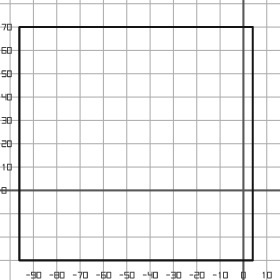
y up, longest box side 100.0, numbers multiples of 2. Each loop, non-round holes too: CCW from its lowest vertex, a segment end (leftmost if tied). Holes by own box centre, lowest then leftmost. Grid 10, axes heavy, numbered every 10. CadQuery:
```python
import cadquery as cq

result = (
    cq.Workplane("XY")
    .moveTo(-96.0, -30.0)
    .lineTo(4.0, -30.0)
    .lineTo(4.0, 70.0)
    .lineTo(-96.0, 70.0)
    .close()
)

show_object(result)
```